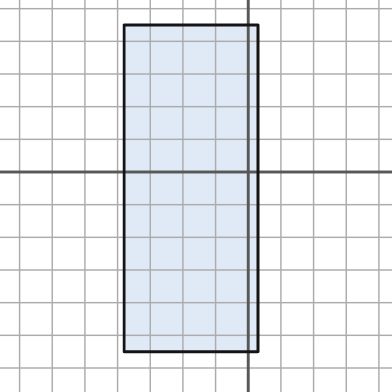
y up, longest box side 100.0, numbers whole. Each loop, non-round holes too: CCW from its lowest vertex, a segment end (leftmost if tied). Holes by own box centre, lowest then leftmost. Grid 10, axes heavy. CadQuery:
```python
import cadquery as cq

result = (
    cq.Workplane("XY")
    .moveTo(-38.0, -55.0)
    .lineTo(3.0, -55.0)
    .lineTo(3.0, 45.0)
    .lineTo(-38.0, 45.0)
    .close()
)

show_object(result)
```